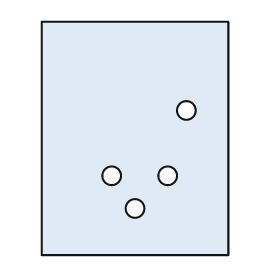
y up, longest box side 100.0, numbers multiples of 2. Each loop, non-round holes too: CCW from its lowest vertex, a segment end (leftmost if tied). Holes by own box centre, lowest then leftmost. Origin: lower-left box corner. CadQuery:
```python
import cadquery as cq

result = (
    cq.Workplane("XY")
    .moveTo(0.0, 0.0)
    .lineTo(80.0, 0.0)
    .lineTo(80.0, 100.0)
    .lineTo(0.0, 100.0)
    .close()
    .moveTo(40.0, 20.0)
    .circle(4.0)
    .moveTo(30.0, 34.0)
    .circle(4.0)
    .moveTo(54.0, 34.0)
    .circle(4.0)
    .moveTo(62.0, 62.0)
    .circle(4.0)
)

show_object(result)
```